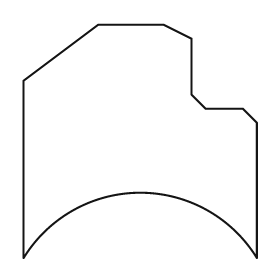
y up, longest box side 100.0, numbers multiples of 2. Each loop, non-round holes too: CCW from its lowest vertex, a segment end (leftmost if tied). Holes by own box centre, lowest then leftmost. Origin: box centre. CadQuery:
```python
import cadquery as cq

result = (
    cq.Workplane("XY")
    .moveTo(-50.0, -50.0)
    .threePointArc((0.0, -22.0), (50.0, -50.0))
    .lineTo(50.0, 8.0)
    .lineTo(44.0, 14.0)
    .lineTo(28.0, 14.0)
    .lineTo(22.0, 20.0)
    .lineTo(22.0, 44.0)
    .lineTo(10.0, 50.0)
    .lineTo(-18.0, 50.0)
    .lineTo(-50.0, 26.0)
    .close()
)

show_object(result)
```